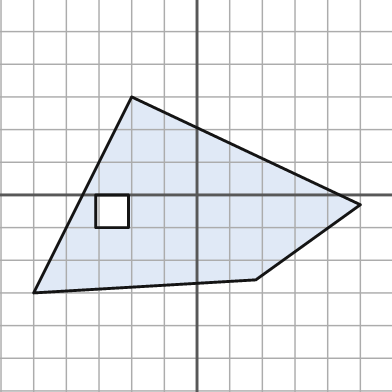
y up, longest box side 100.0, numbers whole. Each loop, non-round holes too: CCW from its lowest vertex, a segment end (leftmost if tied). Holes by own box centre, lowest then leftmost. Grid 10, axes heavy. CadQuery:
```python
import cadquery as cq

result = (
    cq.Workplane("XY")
    .moveTo(-50.0, -30.0)
    .lineTo(18.0, -26.0)
    .lineTo(50.0, -3.0)
    .lineTo(-20.0, 30.0)
    .close()
    .moveTo(-31.0, -10.0)
    .lineTo(-21.0, -10.0)
    .lineTo(-21.0, 0.0)
    .lineTo(-31.0, 0.0)
    .close()
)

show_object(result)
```